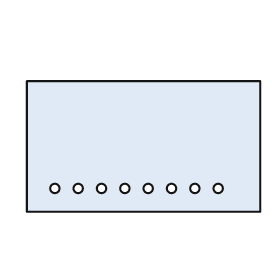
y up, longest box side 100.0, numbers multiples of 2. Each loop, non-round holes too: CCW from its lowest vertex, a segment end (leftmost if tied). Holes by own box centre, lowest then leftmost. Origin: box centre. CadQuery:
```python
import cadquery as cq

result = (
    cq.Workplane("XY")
    .moveTo(-50.0, -28.0)
    .lineTo(50.0, -28.0)
    .lineTo(50.0, 28.0)
    .lineTo(-50.0, 28.0)
    .close()
    .moveTo(-38.0, -18.0)
    .circle(2.0)
    .moveTo(-28.0, -18.0)
    .circle(2.0)
    .moveTo(-18.0, -18.0)
    .circle(2.0)
    .moveTo(-8.0, -18.0)
    .circle(2.0)
    .moveTo(2.0, -18.0)
    .circle(2.0)
    .moveTo(12.0, -18.0)
    .circle(2.0)
    .moveTo(22.0, -18.0)
    .circle(2.0)
    .moveTo(32.0, -18.0)
    .circle(2.0)
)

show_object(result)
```